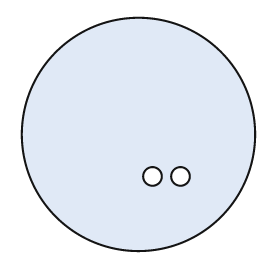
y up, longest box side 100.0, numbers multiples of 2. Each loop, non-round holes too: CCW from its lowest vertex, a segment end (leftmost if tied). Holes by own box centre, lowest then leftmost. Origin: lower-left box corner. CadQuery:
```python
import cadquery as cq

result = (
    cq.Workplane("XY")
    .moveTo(50.0, 50.0)
    .circle(50.0)
    .moveTo(56.0, 32.0)
    .circle(4.0)
    .moveTo(68.0, 32.0)
    .circle(4.0)
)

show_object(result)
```